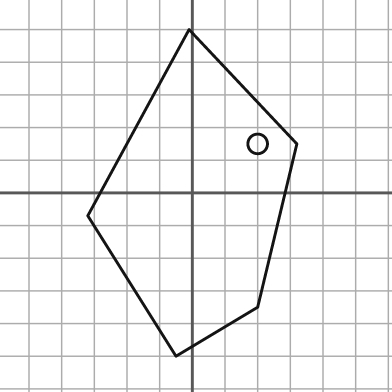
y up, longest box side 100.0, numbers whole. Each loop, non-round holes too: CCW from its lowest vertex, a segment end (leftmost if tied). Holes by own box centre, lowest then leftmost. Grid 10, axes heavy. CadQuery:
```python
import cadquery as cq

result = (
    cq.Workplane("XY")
    .moveTo(-5.0, -50.0)
    .lineTo(20.0, -35.0)
    .lineTo(32.0, 15.0)
    .lineTo(-1.0, 50.0)
    .lineTo(-32.0, -7.0)
    .close()
    .moveTo(20.0, 15.0)
    .circle(3.0)
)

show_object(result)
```